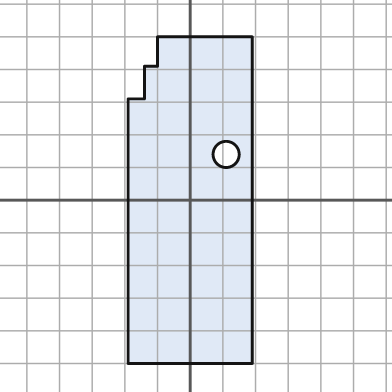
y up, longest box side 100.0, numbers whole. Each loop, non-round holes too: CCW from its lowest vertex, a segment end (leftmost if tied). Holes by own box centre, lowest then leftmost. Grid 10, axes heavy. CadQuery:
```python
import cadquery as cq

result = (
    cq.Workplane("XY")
    .moveTo(-19.0, -50.0)
    .lineTo(19.0, -50.0)
    .lineTo(19.0, 50.0)
    .lineTo(-10.0, 50.0)
    .lineTo(-10.0, 41.0)
    .lineTo(-14.0, 41.0)
    .lineTo(-14.0, 31.0)
    .lineTo(-19.0, 31.0)
    .close()
    .moveTo(11.0, 14.0)
    .circle(4.0)
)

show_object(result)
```